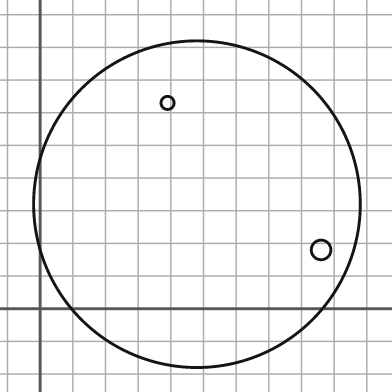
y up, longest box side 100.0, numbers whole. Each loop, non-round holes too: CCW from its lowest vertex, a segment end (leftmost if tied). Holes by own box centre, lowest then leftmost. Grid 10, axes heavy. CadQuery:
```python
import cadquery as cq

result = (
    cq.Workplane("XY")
    .moveTo(48.0, 32.0)
    .circle(50.0)
    .moveTo(86.0, 18.0)
    .circle(3.0)
    .moveTo(39.0, 63.0)
    .circle(2.0)
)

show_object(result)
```